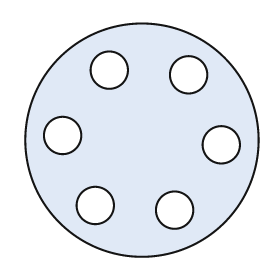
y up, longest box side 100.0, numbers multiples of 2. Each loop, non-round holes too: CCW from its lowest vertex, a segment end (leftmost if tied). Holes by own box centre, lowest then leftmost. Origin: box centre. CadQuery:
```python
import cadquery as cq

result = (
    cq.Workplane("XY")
    .moveTo(0.0, 0.0)
    .circle(50.0)
    .moveTo(14.0, -30.0)
    .circle(8.0)
    .moveTo(-20.0, -28.0)
    .circle(8.0)
    .moveTo(34.0, -2.0)
    .circle(8.0)
    .moveTo(-34.0, 2.0)
    .circle(8.0)
    .moveTo(20.0, 28.0)
    .circle(8.0)
    .moveTo(-14.0, 30.0)
    .circle(8.0)
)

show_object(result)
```